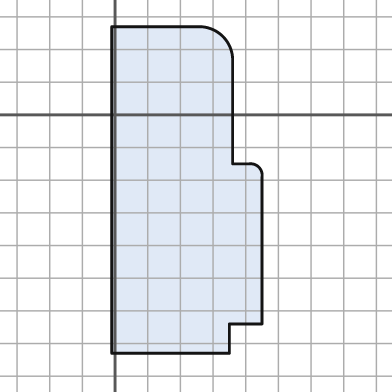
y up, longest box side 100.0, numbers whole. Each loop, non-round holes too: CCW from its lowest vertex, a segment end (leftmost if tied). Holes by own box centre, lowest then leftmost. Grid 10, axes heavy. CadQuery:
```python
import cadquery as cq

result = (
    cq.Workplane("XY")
    .moveTo(-1.0, -73.0)
    .lineTo(35.0, -73.0)
    .lineTo(35.0, -64.0)
    .lineTo(45.0, -64.0)
    .lineTo(45.0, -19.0)
    .threePointArc((44.0, -16.0), (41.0, -15.0))
    .lineTo(36.0, -15.0)
    .lineTo(36.0, 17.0)
    .threePointArc((33.0, 24.0), (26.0, 27.0))
    .lineTo(-1.0, 27.0)
    .close()
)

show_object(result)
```